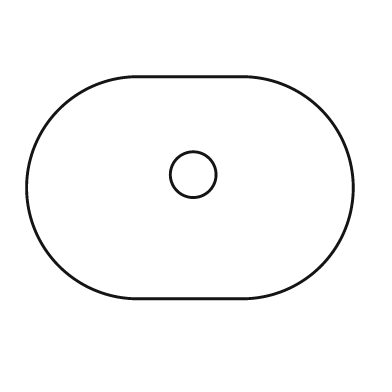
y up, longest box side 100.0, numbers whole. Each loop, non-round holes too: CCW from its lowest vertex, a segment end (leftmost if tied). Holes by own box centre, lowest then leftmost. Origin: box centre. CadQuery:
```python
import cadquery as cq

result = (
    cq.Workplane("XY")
    .moveTo(-16.0, -34.0)
    .lineTo(16.0, -34.0)
    .threePointArc((50.0, 0.0), (16.0, 34.0))
    .lineTo(-16.0, 34.0)
    .threePointArc((-50.0, 0.0), (-16.0, -34.0))
    .close()
    .moveTo(1.0, 4.0)
    .circle(7.0)
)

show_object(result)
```